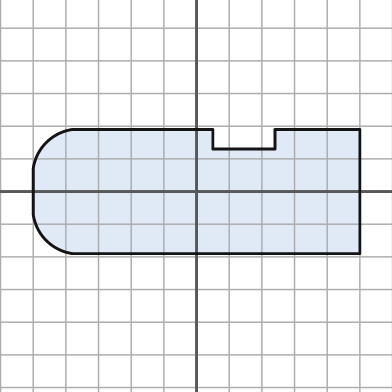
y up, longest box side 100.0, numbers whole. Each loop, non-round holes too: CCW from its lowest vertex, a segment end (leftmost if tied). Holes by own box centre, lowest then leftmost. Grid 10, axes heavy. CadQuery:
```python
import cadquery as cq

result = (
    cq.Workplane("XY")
    .moveTo(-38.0, -19.0)
    .lineTo(50.0, -19.0)
    .lineTo(50.0, 19.0)
    .lineTo(24.0, 19.0)
    .lineTo(24.0, 13.0)
    .lineTo(5.0, 13.0)
    .lineTo(5.0, 19.0)
    .lineTo(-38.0, 19.0)
    .threePointArc((-46.0, 15.0), (-50.0, 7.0))
    .lineTo(-50.0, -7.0)
    .threePointArc((-46.0, -15.0), (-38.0, -19.0))
    .close()
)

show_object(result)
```